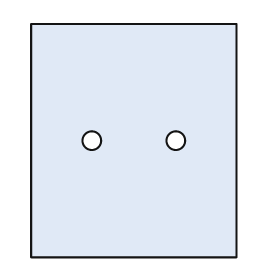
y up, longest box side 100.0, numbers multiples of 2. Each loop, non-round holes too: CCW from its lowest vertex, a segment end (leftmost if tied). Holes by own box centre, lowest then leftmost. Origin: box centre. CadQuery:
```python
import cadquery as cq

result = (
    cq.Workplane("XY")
    .moveTo(-44.0, -50.0)
    .lineTo(44.0, -50.0)
    .lineTo(44.0, 50.0)
    .lineTo(-44.0, 50.0)
    .close()
    .moveTo(-18.0, 0.0)
    .circle(4.0)
    .moveTo(18.0, 0.0)
    .circle(4.0)
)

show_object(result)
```